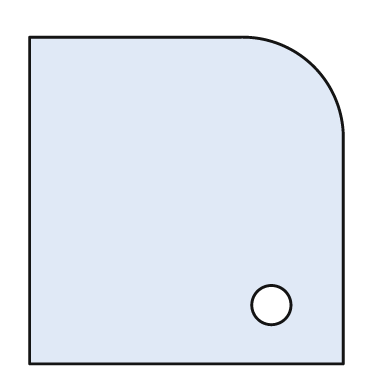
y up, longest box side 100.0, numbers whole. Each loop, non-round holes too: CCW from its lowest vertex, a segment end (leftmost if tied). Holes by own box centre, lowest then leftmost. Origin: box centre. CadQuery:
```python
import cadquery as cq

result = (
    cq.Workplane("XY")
    .moveTo(-48.0, -50.0)
    .lineTo(48.0, -50.0)
    .lineTo(48.0, 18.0)
    .threePointArc((39.0, 41.0), (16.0, 50.0))
    .lineTo(-48.0, 50.0)
    .close()
    .moveTo(26.0, -32.0)
    .circle(6.0)
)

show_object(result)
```